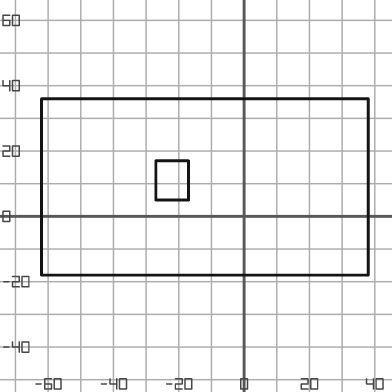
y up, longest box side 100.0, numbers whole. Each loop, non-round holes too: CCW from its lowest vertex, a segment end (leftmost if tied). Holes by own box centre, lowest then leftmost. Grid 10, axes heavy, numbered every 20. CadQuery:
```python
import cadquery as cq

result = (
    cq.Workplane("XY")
    .moveTo(-62.0, -18.0)
    .lineTo(38.0, -18.0)
    .lineTo(38.0, 36.0)
    .lineTo(-62.0, 36.0)
    .close()
    .moveTo(-27.0, 5.0)
    .lineTo(-17.0, 5.0)
    .lineTo(-17.0, 17.0)
    .lineTo(-27.0, 17.0)
    .close()
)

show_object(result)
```